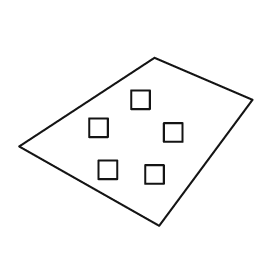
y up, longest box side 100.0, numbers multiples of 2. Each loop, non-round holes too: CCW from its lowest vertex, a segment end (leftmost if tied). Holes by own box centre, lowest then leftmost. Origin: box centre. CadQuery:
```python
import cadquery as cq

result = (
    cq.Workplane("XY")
    .moveTo(10.0, -36.0)
    .lineTo(50.0, 18.0)
    .lineTo(8.0, 36.0)
    .lineTo(-50.0, -2.0)
    .close()
    .moveTo(4.0, -18.0)
    .lineTo(12.0, -18.0)
    .lineTo(12.0, -10.0)
    .lineTo(4.0, -10.0)
    .close()
    .moveTo(-16.0, -16.0)
    .lineTo(-8.0, -16.0)
    .lineTo(-8.0, -8.0)
    .lineTo(-16.0, -8.0)
    .close()
    .moveTo(12.0, 0.0)
    .lineTo(20.0, 0.0)
    .lineTo(20.0, 8.0)
    .lineTo(12.0, 8.0)
    .close()
    .moveTo(-20.0, 2.0)
    .lineTo(-12.0, 2.0)
    .lineTo(-12.0, 10.0)
    .lineTo(-20.0, 10.0)
    .close()
    .moveTo(-2.0, 14.0)
    .lineTo(6.0, 14.0)
    .lineTo(6.0, 22.0)
    .lineTo(-2.0, 22.0)
    .close()
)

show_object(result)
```